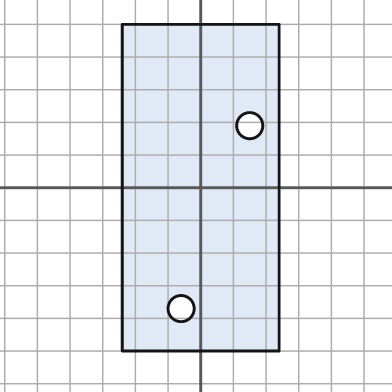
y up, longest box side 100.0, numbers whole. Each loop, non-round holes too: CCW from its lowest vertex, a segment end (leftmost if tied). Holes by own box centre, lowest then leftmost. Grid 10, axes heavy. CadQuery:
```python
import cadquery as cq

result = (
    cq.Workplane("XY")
    .moveTo(-24.0, -50.0)
    .lineTo(24.0, -50.0)
    .lineTo(24.0, 50.0)
    .lineTo(-24.0, 50.0)
    .close()
    .moveTo(-6.0, -37.0)
    .circle(4.0)
    .moveTo(15.0, 19.0)
    .circle(4.0)
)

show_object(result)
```